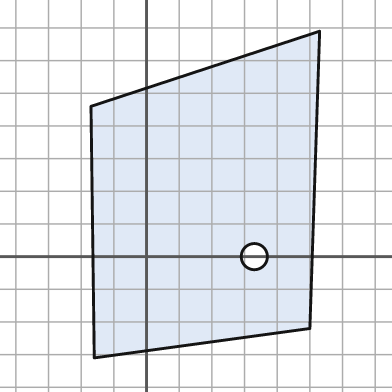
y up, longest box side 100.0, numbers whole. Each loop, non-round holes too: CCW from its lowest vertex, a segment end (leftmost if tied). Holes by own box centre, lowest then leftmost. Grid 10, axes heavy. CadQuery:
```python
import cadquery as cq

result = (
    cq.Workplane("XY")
    .moveTo(-16.0, -31.0)
    .lineTo(50.0, -22.0)
    .lineTo(53.0, 69.0)
    .lineTo(-17.0, 46.0)
    .close()
    .moveTo(33.0, 0.0)
    .circle(4.0)
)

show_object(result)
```